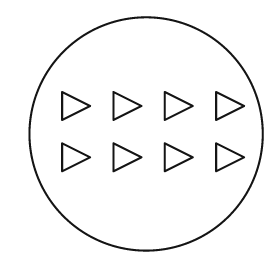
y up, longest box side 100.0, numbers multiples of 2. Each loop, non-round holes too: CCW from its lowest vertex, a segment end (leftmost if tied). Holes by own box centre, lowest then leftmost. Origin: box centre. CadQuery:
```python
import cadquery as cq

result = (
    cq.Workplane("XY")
    .moveTo(0.0, 0.0)
    .circle(50.0)
    .moveTo(-36.0, -16.0)
    .lineTo(-24.0, -10.0)
    .lineTo(-36.0, -4.0)
    .close()
    .moveTo(-14.0, -16.0)
    .lineTo(-2.0, -10.0)
    .lineTo(-14.0, -4.0)
    .close()
    .moveTo(8.0, -16.0)
    .lineTo(20.0, -10.0)
    .lineTo(8.0, -4.0)
    .close()
    .moveTo(30.0, -16.0)
    .lineTo(42.0, -10.0)
    .lineTo(30.0, -4.0)
    .close()
    .moveTo(-36.0, 6.0)
    .lineTo(-24.0, 12.0)
    .lineTo(-36.0, 18.0)
    .close()
    .moveTo(-14.0, 6.0)
    .lineTo(-2.0, 12.0)
    .lineTo(-14.0, 18.0)
    .close()
    .moveTo(8.0, 6.0)
    .lineTo(20.0, 12.0)
    .lineTo(8.0, 18.0)
    .close()
    .moveTo(30.0, 6.0)
    .lineTo(42.0, 12.0)
    .lineTo(30.0, 18.0)
    .close()
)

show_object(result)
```